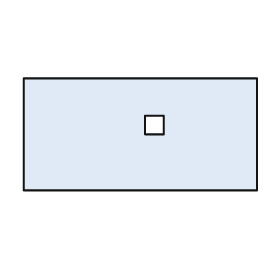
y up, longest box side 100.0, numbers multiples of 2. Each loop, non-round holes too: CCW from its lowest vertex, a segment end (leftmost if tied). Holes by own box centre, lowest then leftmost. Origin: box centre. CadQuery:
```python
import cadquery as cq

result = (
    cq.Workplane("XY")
    .moveTo(-50.0, -24.0)
    .lineTo(50.0, -24.0)
    .lineTo(50.0, 24.0)
    .lineTo(-50.0, 24.0)
    .close()
    .moveTo(2.0, 0.0)
    .lineTo(10.0, 0.0)
    .lineTo(10.0, 8.0)
    .lineTo(2.0, 8.0)
    .close()
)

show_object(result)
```